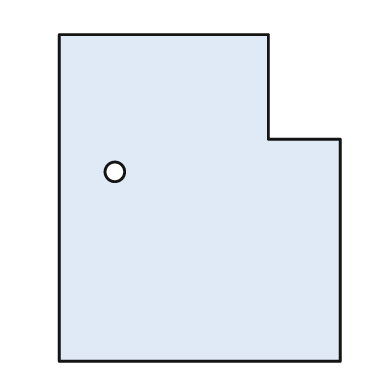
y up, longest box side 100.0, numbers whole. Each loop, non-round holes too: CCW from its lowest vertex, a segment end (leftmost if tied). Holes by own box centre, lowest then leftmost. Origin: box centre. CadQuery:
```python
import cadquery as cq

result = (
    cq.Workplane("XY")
    .moveTo(-43.0, -50.0)
    .lineTo(43.0, -50.0)
    .lineTo(43.0, 18.0)
    .lineTo(21.0, 18.0)
    .lineTo(21.0, 50.0)
    .lineTo(-43.0, 50.0)
    .close()
    .moveTo(-26.0, 8.0)
    .circle(3.0)
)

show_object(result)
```